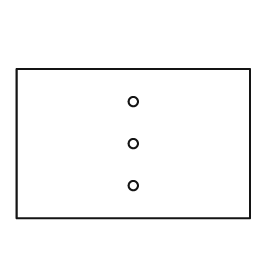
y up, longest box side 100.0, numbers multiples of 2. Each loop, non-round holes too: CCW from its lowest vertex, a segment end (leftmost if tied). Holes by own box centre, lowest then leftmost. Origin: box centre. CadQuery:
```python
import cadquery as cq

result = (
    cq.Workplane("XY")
    .moveTo(-50.0, -32.0)
    .lineTo(50.0, -32.0)
    .lineTo(50.0, 32.0)
    .lineTo(-50.0, 32.0)
    .close()
    .moveTo(0.0, -18.0)
    .circle(2.0)
    .moveTo(0.0, 0.0)
    .circle(2.0)
    .moveTo(0.0, 18.0)
    .circle(2.0)
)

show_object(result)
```